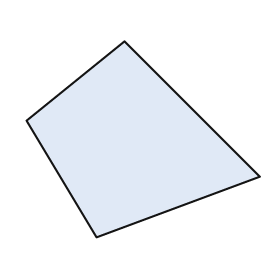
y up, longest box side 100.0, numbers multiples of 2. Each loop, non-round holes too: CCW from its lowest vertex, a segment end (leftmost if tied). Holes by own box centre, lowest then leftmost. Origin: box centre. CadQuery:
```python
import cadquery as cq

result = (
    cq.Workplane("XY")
    .moveTo(-20.0, -42.0)
    .lineTo(50.0, -16.0)
    .lineTo(-8.0, 42.0)
    .lineTo(-50.0, 8.0)
    .close()
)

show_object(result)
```